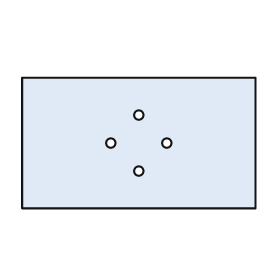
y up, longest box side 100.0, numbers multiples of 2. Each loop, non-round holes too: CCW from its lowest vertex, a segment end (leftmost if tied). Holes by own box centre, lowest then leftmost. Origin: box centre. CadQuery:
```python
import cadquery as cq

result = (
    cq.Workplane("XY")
    .moveTo(-50.0, -28.0)
    .lineTo(50.0, -28.0)
    .lineTo(50.0, 28.0)
    .lineTo(-50.0, 28.0)
    .close()
    .moveTo(0.0, -12.0)
    .circle(2.0)
    .moveTo(-12.0, 0.0)
    .circle(2.0)
    .moveTo(12.0, 0.0)
    .circle(2.0)
    .moveTo(0.0, 12.0)
    .circle(2.0)
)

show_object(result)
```